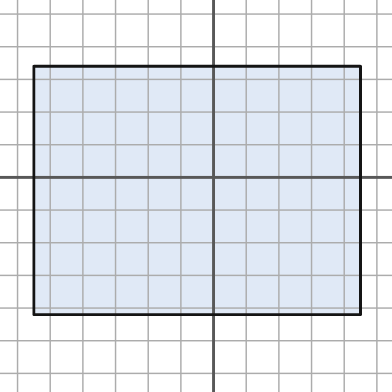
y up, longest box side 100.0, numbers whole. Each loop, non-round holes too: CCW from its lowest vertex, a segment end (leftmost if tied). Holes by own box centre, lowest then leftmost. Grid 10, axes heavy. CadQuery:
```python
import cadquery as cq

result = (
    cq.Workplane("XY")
    .moveTo(-55.0, -42.0)
    .lineTo(45.0, -42.0)
    .lineTo(45.0, 34.0)
    .lineTo(-55.0, 34.0)
    .close()
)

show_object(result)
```